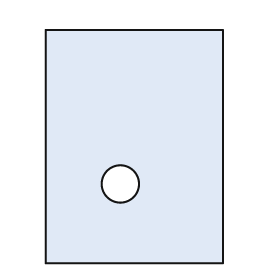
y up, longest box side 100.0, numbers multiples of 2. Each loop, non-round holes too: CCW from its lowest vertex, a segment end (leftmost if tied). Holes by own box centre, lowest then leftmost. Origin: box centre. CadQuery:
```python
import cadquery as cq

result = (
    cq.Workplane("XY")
    .moveTo(-38.0, -50.0)
    .lineTo(38.0, -50.0)
    .lineTo(38.0, 50.0)
    .lineTo(-38.0, 50.0)
    .close()
    .moveTo(-6.0, -16.0)
    .circle(8.0)
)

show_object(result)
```